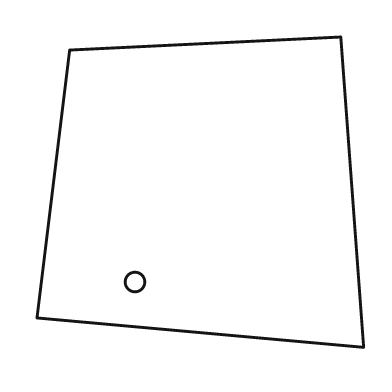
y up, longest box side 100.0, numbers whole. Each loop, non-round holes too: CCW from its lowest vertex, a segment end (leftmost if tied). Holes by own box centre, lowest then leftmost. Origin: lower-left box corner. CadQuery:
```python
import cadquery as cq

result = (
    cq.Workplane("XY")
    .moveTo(100.0, 0.0)
    .lineTo(93.0, 95.0)
    .lineTo(10.0, 91.0)
    .lineTo(0.0, 9.0)
    .close()
    .moveTo(30.0, 20.0)
    .circle(3.0)
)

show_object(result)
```